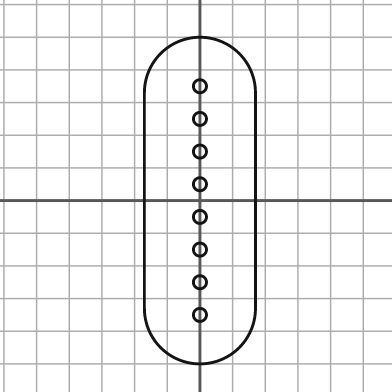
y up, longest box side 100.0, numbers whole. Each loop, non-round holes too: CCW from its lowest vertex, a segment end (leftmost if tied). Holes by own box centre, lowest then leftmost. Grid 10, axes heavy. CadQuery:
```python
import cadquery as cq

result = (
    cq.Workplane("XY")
    .moveTo(-17.0, -33.0)
    .threePointArc((0.0, -50.0), (17.0, -33.0))
    .lineTo(17.0, 33.0)
    .threePointArc((0.0, 50.0), (-17.0, 33.0))
    .close()
    .moveTo(0.0, -35.0)
    .circle(2.0)
    .moveTo(0.0, -25.0)
    .circle(2.0)
    .moveTo(0.0, -15.0)
    .circle(2.0)
    .moveTo(0.0, -5.0)
    .circle(2.0)
    .moveTo(0.0, 5.0)
    .circle(2.0)
    .moveTo(0.0, 15.0)
    .circle(2.0)
    .moveTo(0.0, 25.0)
    .circle(2.0)
    .moveTo(0.0, 35.0)
    .circle(2.0)
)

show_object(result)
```